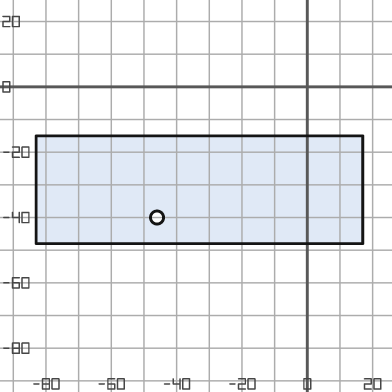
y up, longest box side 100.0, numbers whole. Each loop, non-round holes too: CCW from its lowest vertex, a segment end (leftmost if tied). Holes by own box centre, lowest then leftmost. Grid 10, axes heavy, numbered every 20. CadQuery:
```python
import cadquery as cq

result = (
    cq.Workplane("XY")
    .moveTo(-83.0, -48.0)
    .lineTo(17.0, -48.0)
    .lineTo(17.0, -15.0)
    .lineTo(-83.0, -15.0)
    .close()
    .moveTo(-46.0, -40.0)
    .circle(2.0)
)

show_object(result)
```